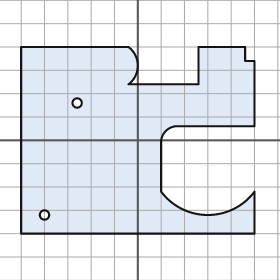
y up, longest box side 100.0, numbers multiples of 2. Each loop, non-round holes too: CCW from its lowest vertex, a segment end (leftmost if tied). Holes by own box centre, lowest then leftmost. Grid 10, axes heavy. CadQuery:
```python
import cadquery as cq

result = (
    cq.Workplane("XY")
    .moveTo(-50.0, -40.0)
    .lineTo(50.0, -40.0)
    .lineTo(50.0, -22.0)
    .threePointArc((30.0, -32.0), (10.0, -22.0))
    .lineTo(10.0, 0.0)
    .threePointArc((12.0, 4.0), (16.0, 6.0))
    .lineTo(50.0, 6.0)
    .lineTo(50.0, 34.0)
    .lineTo(46.0, 34.0)
    .lineTo(46.0, 40.0)
    .lineTo(26.0, 40.0)
    .lineTo(26.0, 24.0)
    .lineTo(-4.0, 24.0)
    .threePointArc((0.0, 32.0), (-4.0, 40.0))
    .lineTo(-50.0, 40.0)
    .close()
    .moveTo(-40.0, -32.0)
    .circle(2.0)
    .moveTo(-26.0, 16.0)
    .circle(2.0)
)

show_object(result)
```